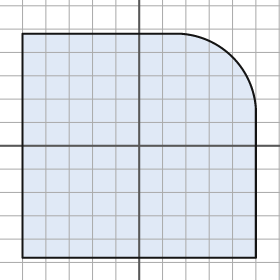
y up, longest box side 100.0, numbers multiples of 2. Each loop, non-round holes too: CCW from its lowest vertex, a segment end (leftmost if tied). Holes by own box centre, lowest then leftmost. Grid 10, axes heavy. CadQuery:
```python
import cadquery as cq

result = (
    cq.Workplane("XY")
    .moveTo(-50.0, -48.0)
    .lineTo(50.0, -48.0)
    .lineTo(50.0, 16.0)
    .threePointArc((40.0, 38.0), (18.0, 48.0))
    .lineTo(-50.0, 48.0)
    .close()
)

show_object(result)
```